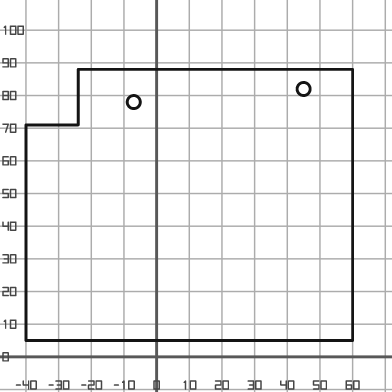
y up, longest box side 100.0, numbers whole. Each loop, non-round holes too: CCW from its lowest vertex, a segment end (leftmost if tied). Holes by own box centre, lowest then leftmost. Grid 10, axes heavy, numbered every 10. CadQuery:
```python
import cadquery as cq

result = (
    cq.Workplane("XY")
    .moveTo(-40.0, 5.0)
    .lineTo(60.0, 5.0)
    .lineTo(60.0, 88.0)
    .lineTo(-24.0, 88.0)
    .lineTo(-24.0, 71.0)
    .lineTo(-40.0, 71.0)
    .close()
    .moveTo(-7.0, 78.0)
    .circle(2.0)
    .moveTo(45.0, 82.0)
    .circle(2.0)
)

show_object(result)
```